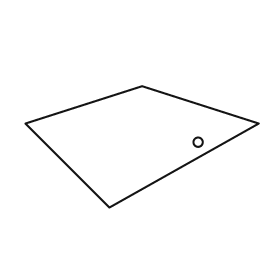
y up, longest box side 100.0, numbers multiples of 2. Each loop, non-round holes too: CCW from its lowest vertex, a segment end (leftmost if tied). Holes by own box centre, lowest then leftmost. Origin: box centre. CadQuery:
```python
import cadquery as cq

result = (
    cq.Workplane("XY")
    .moveTo(-14.0, -26.0)
    .lineTo(50.0, 10.0)
    .lineTo(0.0, 26.0)
    .lineTo(-50.0, 10.0)
    .close()
    .moveTo(24.0, 2.0)
    .circle(2.0)
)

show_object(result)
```